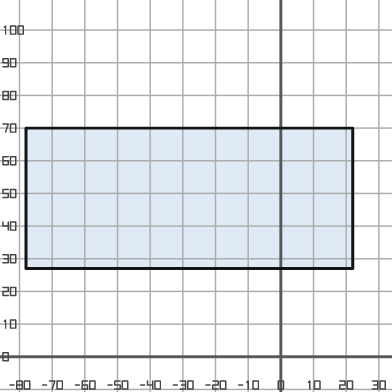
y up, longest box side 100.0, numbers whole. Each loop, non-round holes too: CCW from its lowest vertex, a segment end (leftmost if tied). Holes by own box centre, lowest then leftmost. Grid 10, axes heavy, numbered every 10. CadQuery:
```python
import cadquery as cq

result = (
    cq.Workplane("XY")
    .moveTo(-78.0, 27.0)
    .lineTo(22.0, 27.0)
    .lineTo(22.0, 70.0)
    .lineTo(-78.0, 70.0)
    .close()
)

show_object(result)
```